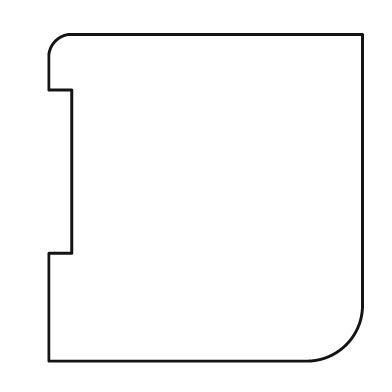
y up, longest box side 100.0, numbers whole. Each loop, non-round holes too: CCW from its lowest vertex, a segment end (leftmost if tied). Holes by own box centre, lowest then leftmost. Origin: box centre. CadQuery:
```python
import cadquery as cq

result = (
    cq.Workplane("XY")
    .moveTo(-48.0, -50.0)
    .lineTo(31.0, -50.0)
    .threePointArc((43.0, -45.0), (48.0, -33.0))
    .lineTo(48.0, 50.0)
    .lineTo(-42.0, 50.0)
    .threePointArc((-46.0, 48.0), (-48.0, 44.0))
    .lineTo(-48.0, 33.0)
    .lineTo(-41.0, 33.0)
    .lineTo(-41.0, -17.0)
    .lineTo(-48.0, -17.0)
    .close()
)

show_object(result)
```